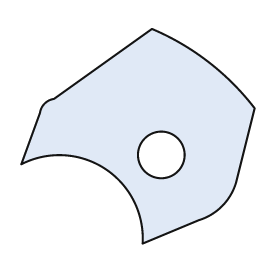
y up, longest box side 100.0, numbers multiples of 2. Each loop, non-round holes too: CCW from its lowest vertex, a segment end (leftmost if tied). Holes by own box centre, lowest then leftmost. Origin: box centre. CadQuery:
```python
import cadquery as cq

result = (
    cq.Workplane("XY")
    .moveTo(2.0, -46.0)
    .lineTo(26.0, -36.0)
    .threePointArc((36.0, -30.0), (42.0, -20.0))
    .lineTo(50.0, 12.0)
    .threePointArc((30.0, 32.0), (6.0, 46.0))
    .lineTo(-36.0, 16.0)
    .threePointArc((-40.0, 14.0), (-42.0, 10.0))
    .lineTo(-50.0, -12.0)
    .threePointArc((-14.0, -14.0), (2.0, -46.0))
    .close()
    .moveTo(10.0, -8.0)
    .circle(10.0)
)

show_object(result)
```